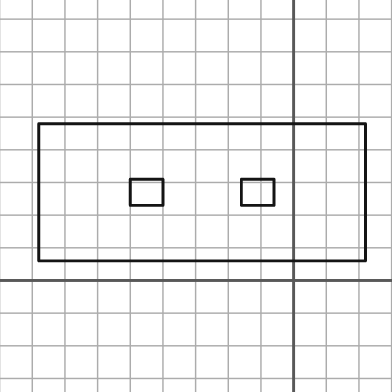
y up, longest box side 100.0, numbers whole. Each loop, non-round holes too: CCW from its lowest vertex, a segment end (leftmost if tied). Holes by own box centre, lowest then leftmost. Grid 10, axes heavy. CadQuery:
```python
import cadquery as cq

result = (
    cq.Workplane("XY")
    .moveTo(-78.0, 6.0)
    .lineTo(22.0, 6.0)
    .lineTo(22.0, 48.0)
    .lineTo(-78.0, 48.0)
    .close()
    .moveTo(-50.0, 23.0)
    .lineTo(-40.0, 23.0)
    .lineTo(-40.0, 31.0)
    .lineTo(-50.0, 31.0)
    .close()
    .moveTo(-16.0, 23.0)
    .lineTo(-6.0, 23.0)
    .lineTo(-6.0, 31.0)
    .lineTo(-16.0, 31.0)
    .close()
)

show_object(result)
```